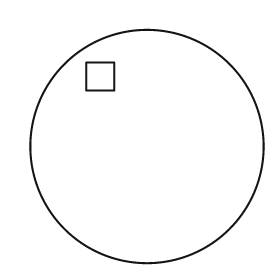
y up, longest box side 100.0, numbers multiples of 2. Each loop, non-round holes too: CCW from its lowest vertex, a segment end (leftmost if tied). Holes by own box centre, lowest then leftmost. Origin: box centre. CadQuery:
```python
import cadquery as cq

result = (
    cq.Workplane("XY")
    .moveTo(0.0, 0.0)
    .circle(50.0)
    .moveTo(-26.0, 24.0)
    .lineTo(-14.0, 24.0)
    .lineTo(-14.0, 36.0)
    .lineTo(-26.0, 36.0)
    .close()
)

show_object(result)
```